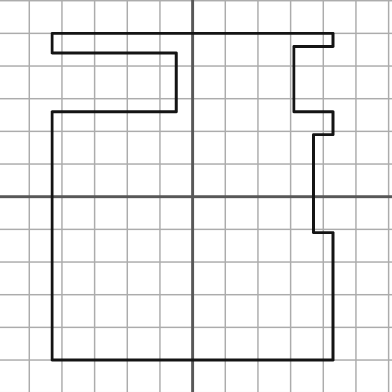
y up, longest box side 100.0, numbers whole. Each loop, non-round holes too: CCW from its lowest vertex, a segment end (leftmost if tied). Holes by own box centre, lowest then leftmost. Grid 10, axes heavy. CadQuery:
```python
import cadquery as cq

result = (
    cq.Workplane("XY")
    .moveTo(-43.0, -50.0)
    .lineTo(43.0, -50.0)
    .lineTo(43.0, -11.0)
    .lineTo(37.0, -11.0)
    .lineTo(37.0, 19.0)
    .lineTo(43.0, 19.0)
    .lineTo(43.0, 26.0)
    .lineTo(31.0, 26.0)
    .lineTo(31.0, 46.0)
    .lineTo(43.0, 46.0)
    .lineTo(43.0, 50.0)
    .lineTo(-43.0, 50.0)
    .lineTo(-43.0, 44.0)
    .lineTo(-5.0, 44.0)
    .lineTo(-5.0, 26.0)
    .lineTo(-43.0, 26.0)
    .close()
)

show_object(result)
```